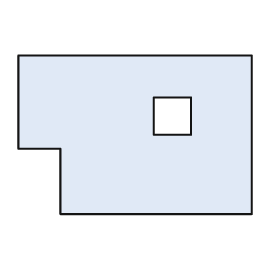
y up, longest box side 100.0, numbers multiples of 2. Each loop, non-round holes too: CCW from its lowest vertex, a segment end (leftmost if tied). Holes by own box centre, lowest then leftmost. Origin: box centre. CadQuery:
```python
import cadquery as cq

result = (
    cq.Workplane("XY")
    .moveTo(-32.0, -34.0)
    .lineTo(50.0, -34.0)
    .lineTo(50.0, 34.0)
    .lineTo(-50.0, 34.0)
    .lineTo(-50.0, -6.0)
    .lineTo(-32.0, -6.0)
    .close()
    .moveTo(8.0, 0.0)
    .lineTo(24.0, 0.0)
    .lineTo(24.0, 16.0)
    .lineTo(8.0, 16.0)
    .close()
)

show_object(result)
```